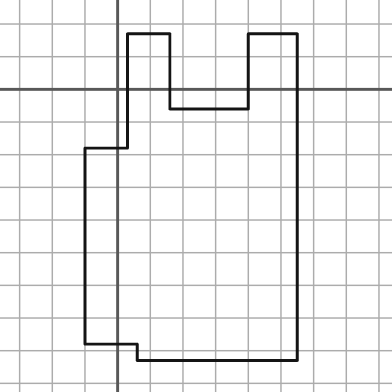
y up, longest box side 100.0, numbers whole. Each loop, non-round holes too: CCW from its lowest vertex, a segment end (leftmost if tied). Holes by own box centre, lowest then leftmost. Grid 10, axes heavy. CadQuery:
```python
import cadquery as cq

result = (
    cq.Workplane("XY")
    .moveTo(6.0, -83.0)
    .lineTo(55.0, -83.0)
    .lineTo(55.0, 17.0)
    .lineTo(40.0, 17.0)
    .lineTo(40.0, -6.0)
    .lineTo(16.0, -6.0)
    .lineTo(16.0, 17.0)
    .lineTo(3.0, 17.0)
    .lineTo(3.0, -18.0)
    .lineTo(-10.0, -18.0)
    .lineTo(-10.0, -78.0)
    .lineTo(6.0, -78.0)
    .close()
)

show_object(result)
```